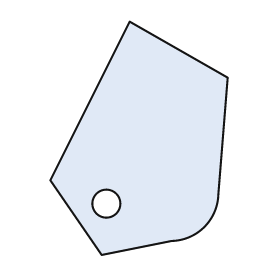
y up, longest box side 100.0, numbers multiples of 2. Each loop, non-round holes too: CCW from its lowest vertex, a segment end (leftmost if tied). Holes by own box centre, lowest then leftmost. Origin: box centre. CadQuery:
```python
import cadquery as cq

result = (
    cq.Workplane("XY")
    .moveTo(-16.0, -50.0)
    .lineTo(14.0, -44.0)
    .threePointArc((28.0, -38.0), (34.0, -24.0))
    .lineTo(38.0, 26.0)
    .lineTo(-4.0, 50.0)
    .lineTo(-38.0, -18.0)
    .close()
    .moveTo(-14.0, -28.0)
    .circle(6.0)
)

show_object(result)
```